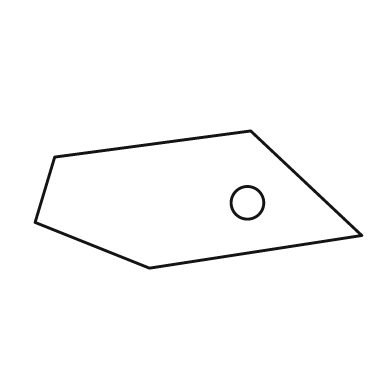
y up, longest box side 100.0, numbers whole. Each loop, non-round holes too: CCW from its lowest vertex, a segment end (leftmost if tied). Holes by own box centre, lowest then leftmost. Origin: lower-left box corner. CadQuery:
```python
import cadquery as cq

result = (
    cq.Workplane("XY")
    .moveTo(35.0, 0.0)
    .lineTo(100.0, 10.0)
    .lineTo(66.0, 42.0)
    .lineTo(6.0, 34.0)
    .lineTo(0.0, 14.0)
    .close()
    .moveTo(65.0, 20.0)
    .circle(5.0)
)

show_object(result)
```